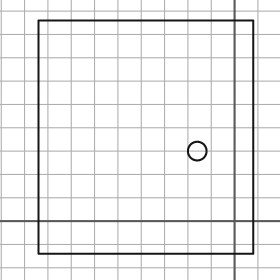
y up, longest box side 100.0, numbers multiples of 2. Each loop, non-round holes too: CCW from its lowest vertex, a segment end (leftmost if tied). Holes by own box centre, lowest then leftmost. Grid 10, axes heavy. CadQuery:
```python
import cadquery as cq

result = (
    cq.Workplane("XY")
    .moveTo(-84.0, -14.0)
    .lineTo(8.0, -14.0)
    .lineTo(8.0, 86.0)
    .lineTo(-84.0, 86.0)
    .close()
    .moveTo(-16.0, 30.0)
    .circle(4.0)
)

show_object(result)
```